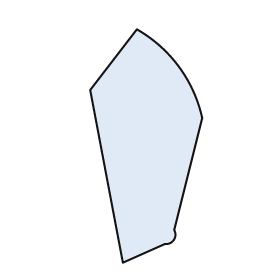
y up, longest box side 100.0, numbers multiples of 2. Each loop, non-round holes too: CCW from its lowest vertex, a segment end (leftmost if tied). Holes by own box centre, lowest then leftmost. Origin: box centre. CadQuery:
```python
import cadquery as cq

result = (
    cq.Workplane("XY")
    .moveTo(-10.0, -50.0)
    .lineTo(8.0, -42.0)
    .threePointArc((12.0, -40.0), (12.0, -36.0))
    .lineTo(24.0, 12.0)
    .threePointArc((14.0, 34.0), (-4.0, 50.0))
    .lineTo(-24.0, 24.0)
    .close()
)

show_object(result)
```